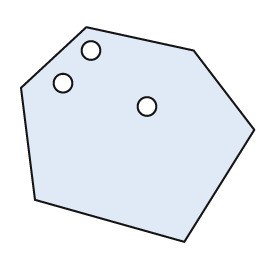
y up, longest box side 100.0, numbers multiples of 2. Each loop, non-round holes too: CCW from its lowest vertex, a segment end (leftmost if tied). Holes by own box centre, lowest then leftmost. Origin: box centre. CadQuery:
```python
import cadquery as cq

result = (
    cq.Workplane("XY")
    .moveTo(20.0, -46.0)
    .lineTo(50.0, 2.0)
    .lineTo(24.0, 36.0)
    .lineTo(-22.0, 46.0)
    .lineTo(-50.0, 20.0)
    .lineTo(-44.0, -28.0)
    .close()
    .moveTo(4.0, 12.0)
    .circle(4.0)
    .moveTo(-32.0, 22.0)
    .circle(4.0)
    .moveTo(-20.0, 36.0)
    .circle(4.0)
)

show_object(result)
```